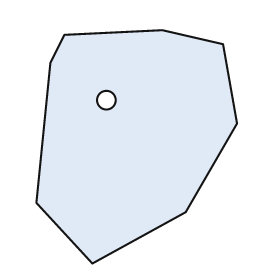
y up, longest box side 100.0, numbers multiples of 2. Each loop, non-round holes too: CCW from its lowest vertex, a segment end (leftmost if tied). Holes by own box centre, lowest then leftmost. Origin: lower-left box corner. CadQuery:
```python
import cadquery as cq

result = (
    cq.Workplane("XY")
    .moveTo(24.0, 0.0)
    .lineTo(64.0, 22.0)
    .lineTo(86.0, 60.0)
    .lineTo(80.0, 94.0)
    .lineTo(54.0, 100.0)
    .lineTo(12.0, 98.0)
    .lineTo(6.0, 86.0)
    .lineTo(0.0, 26.0)
    .close()
    .moveTo(30.0, 70.0)
    .circle(4.0)
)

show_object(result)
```